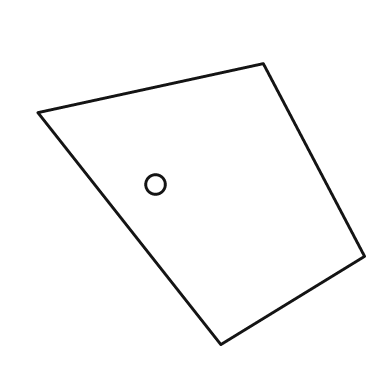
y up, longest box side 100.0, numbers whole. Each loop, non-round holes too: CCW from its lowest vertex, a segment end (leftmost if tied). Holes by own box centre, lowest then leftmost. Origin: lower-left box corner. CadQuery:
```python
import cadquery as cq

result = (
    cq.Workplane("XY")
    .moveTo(56.0, 0.0)
    .lineTo(100.0, 27.0)
    .lineTo(69.0, 86.0)
    .lineTo(0.0, 71.0)
    .close()
    .moveTo(36.0, 49.0)
    .circle(3.0)
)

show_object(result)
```